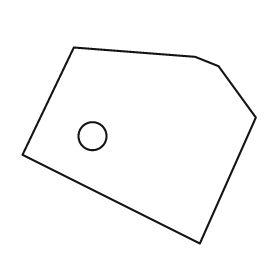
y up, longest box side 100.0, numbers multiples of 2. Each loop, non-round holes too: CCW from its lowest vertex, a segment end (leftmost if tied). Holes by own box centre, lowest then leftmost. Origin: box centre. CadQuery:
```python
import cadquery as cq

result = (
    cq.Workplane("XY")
    .moveTo(26.0, -42.0)
    .lineTo(50.0, 12.0)
    .lineTo(34.0, 34.0)
    .lineTo(24.0, 38.0)
    .lineTo(-28.0, 42.0)
    .lineTo(-50.0, -4.0)
    .close()
    .moveTo(-20.0, 4.0)
    .circle(6.0)
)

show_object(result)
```